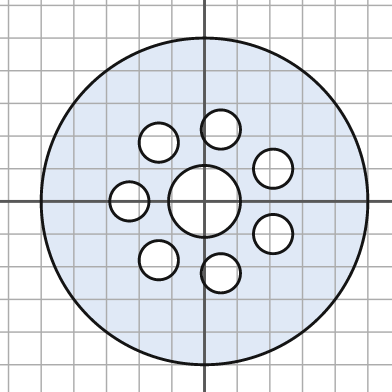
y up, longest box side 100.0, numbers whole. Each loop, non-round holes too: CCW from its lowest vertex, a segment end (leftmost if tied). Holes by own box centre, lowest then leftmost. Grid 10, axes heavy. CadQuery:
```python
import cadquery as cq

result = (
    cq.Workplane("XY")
    .moveTo(0.0, 0.0)
    .circle(50.0)
    .moveTo(5.0, -22.0)
    .circle(6.0)
    .moveTo(-14.0, -18.0)
    .circle(6.0)
    .moveTo(21.0, -10.0)
    .circle(6.0)
    .moveTo(-23.0, 0.0)
    .circle(6.0)
    .moveTo(0.0, 0.0)
    .circle(11.0)
    .moveTo(21.0, 10.0)
    .circle(6.0)
    .moveTo(-14.0, 18.0)
    .circle(6.0)
    .moveTo(5.0, 22.0)
    .circle(6.0)
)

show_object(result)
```